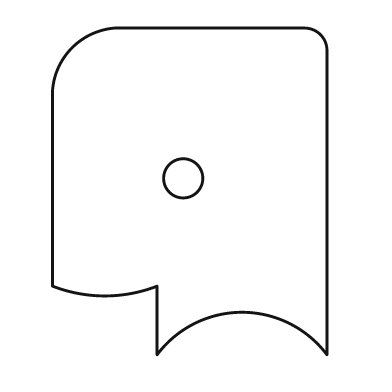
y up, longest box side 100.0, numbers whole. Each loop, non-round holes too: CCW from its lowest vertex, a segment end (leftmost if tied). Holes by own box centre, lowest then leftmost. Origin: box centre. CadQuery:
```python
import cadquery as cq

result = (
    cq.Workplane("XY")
    .moveTo(-10.0, -50.0)
    .threePointArc((16.0, -37.0), (42.0, -50.0))
    .lineTo(42.0, 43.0)
    .threePointArc((40.0, 48.0), (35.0, 50.0))
    .lineTo(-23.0, 50.0)
    .threePointArc((-36.0, 44.0), (-42.0, 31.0))
    .lineTo(-42.0, -29.0)
    .threePointArc((-26.0, -32.0), (-10.0, -29.0))
    .close()
    .moveTo(-2.0, 4.0)
    .circle(6.0)
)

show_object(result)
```